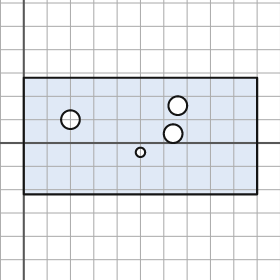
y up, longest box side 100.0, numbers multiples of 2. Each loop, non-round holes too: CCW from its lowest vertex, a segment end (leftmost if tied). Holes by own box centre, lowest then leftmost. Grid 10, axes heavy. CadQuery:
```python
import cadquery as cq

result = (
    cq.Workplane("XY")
    .moveTo(0.0, -22.0)
    .lineTo(100.0, -22.0)
    .lineTo(100.0, 28.0)
    .lineTo(0.0, 28.0)
    .close()
    .moveTo(50.0, -4.0)
    .circle(2.0)
    .moveTo(64.0, 4.0)
    .circle(4.0)
    .moveTo(20.0, 10.0)
    .circle(4.0)
    .moveTo(66.0, 16.0)
    .circle(4.0)
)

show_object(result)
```